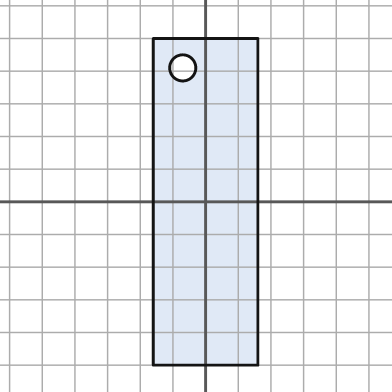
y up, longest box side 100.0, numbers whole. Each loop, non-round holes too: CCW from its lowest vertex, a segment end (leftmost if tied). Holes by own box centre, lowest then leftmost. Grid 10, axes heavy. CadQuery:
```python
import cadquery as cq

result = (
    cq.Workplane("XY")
    .moveTo(-16.0, -50.0)
    .lineTo(16.0, -50.0)
    .lineTo(16.0, 50.0)
    .lineTo(-16.0, 50.0)
    .close()
    .moveTo(-7.0, 41.0)
    .circle(4.0)
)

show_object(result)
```